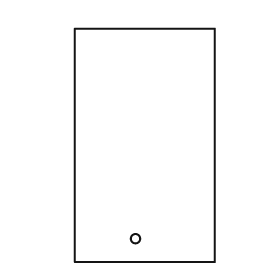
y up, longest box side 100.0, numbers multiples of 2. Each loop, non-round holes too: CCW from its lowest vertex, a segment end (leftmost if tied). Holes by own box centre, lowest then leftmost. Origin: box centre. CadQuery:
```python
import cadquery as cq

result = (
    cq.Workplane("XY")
    .moveTo(-30.0, -50.0)
    .lineTo(30.0, -50.0)
    .lineTo(30.0, 50.0)
    .lineTo(-30.0, 50.0)
    .close()
    .moveTo(-4.0, -40.0)
    .circle(2.0)
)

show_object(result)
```